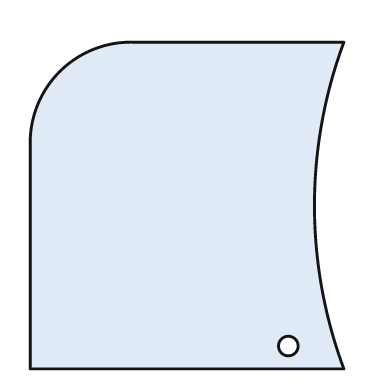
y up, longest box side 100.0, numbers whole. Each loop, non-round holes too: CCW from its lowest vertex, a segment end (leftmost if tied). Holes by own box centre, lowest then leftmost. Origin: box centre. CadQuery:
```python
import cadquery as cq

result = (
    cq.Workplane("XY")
    .moveTo(-48.0, -50.0)
    .lineTo(48.0, -50.0)
    .threePointArc((39.0, 0.0), (48.0, 50.0))
    .lineTo(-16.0, 50.0)
    .threePointArc((-39.0, 41.0), (-48.0, 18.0))
    .close()
    .moveTo(31.0, -43.0)
    .circle(3.0)
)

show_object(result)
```